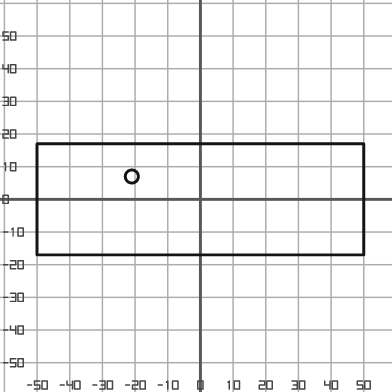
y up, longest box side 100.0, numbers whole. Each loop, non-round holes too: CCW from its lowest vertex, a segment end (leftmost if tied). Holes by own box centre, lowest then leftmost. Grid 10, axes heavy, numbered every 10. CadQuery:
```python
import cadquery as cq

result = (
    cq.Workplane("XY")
    .moveTo(-50.0, -17.0)
    .lineTo(50.0, -17.0)
    .lineTo(50.0, 17.0)
    .lineTo(-50.0, 17.0)
    .close()
    .moveTo(-21.0, 7.0)
    .circle(2.0)
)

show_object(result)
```